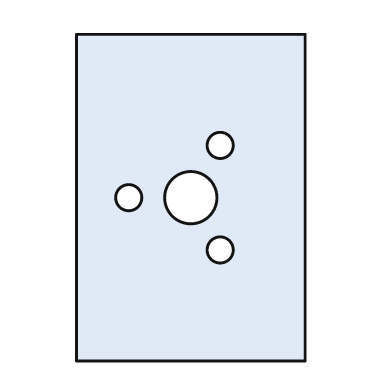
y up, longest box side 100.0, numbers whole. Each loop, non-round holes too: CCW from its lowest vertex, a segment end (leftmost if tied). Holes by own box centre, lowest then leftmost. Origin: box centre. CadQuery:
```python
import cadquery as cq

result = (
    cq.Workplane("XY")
    .moveTo(-35.0, -50.0)
    .lineTo(35.0, -50.0)
    .lineTo(35.0, 50.0)
    .lineTo(-35.0, 50.0)
    .close()
    .moveTo(9.0, -16.0)
    .circle(4.0)
    .moveTo(-19.0, 0.0)
    .circle(4.0)
    .moveTo(0.0, 0.0)
    .circle(8.0)
    .moveTo(9.0, 16.0)
    .circle(4.0)
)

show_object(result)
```